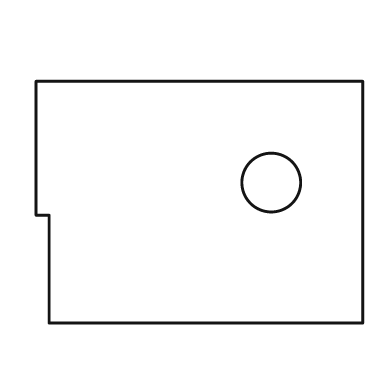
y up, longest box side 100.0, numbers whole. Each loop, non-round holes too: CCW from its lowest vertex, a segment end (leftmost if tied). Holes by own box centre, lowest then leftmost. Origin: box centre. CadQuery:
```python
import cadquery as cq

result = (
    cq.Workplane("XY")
    .moveTo(-46.0, -37.0)
    .lineTo(50.0, -37.0)
    .lineTo(50.0, 37.0)
    .lineTo(-50.0, 37.0)
    .lineTo(-50.0, -4.0)
    .lineTo(-46.0, -4.0)
    .close()
    .moveTo(22.0, 6.0)
    .circle(9.0)
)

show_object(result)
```